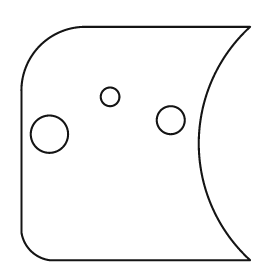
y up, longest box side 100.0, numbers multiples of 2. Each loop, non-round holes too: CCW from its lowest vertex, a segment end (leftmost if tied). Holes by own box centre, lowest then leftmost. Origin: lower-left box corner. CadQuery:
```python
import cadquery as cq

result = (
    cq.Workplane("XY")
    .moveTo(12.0, 0.0)
    .lineTo(98.0, 0.0)
    .threePointArc((76.0, 50.0), (98.0, 100.0))
    .lineTo(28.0, 100.0)
    .threePointArc((8.0, 92.0), (0.0, 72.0))
    .lineTo(0.0, 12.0)
    .threePointArc((4.0, 4.0), (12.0, 0.0))
    .close()
    .moveTo(12.0, 54.0)
    .circle(8.0)
    .moveTo(64.0, 60.0)
    .circle(6.0)
    .moveTo(38.0, 70.0)
    .circle(4.0)
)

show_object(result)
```